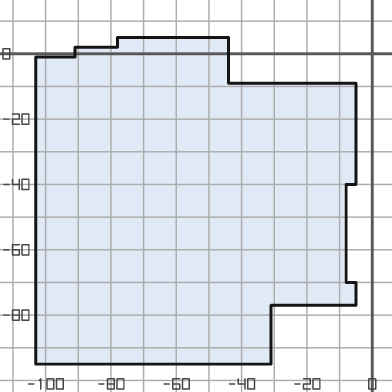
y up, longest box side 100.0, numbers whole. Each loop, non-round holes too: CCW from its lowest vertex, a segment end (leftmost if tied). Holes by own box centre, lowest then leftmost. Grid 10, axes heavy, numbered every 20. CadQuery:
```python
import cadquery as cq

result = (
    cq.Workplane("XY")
    .moveTo(-103.0, -95.0)
    .lineTo(-31.0, -95.0)
    .lineTo(-31.0, -77.0)
    .lineTo(-5.0, -77.0)
    .lineTo(-5.0, -70.0)
    .lineTo(-8.0, -70.0)
    .lineTo(-8.0, -40.0)
    .lineTo(-5.0, -40.0)
    .lineTo(-5.0, -9.0)
    .lineTo(-44.0, -9.0)
    .lineTo(-44.0, 5.0)
    .lineTo(-78.0, 5.0)
    .lineTo(-78.0, 2.0)
    .lineTo(-91.0, 2.0)
    .lineTo(-91.0, -1.0)
    .lineTo(-103.0, -1.0)
    .close()
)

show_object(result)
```